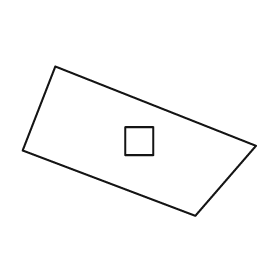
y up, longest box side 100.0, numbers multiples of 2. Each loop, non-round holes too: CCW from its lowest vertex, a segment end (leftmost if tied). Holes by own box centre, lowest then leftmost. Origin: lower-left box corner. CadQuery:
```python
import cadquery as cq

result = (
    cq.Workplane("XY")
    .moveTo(74.0, 0.0)
    .lineTo(100.0, 30.0)
    .lineTo(14.0, 64.0)
    .lineTo(0.0, 28.0)
    .close()
    .moveTo(44.0, 26.0)
    .lineTo(56.0, 26.0)
    .lineTo(56.0, 38.0)
    .lineTo(44.0, 38.0)
    .close()
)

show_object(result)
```